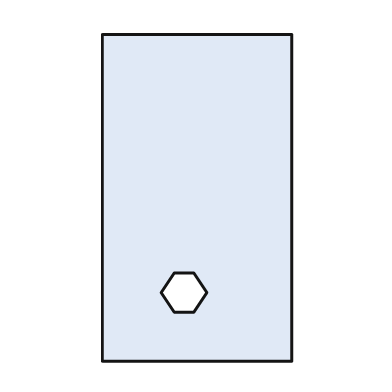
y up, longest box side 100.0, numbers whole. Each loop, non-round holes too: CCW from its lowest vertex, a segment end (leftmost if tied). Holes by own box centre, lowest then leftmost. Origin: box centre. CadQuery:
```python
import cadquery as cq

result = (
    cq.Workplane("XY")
    .moveTo(-29.0, -50.0)
    .lineTo(29.0, -50.0)
    .lineTo(29.0, 50.0)
    .lineTo(-29.0, 50.0)
    .close()
    .moveTo(-7.0, -35.0)
    .lineTo(-1.0, -35.0)
    .lineTo(3.0, -29.0)
    .lineTo(-1.0, -23.0)
    .lineTo(-7.0, -23.0)
    .lineTo(-11.0, -29.0)
    .close()
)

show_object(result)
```